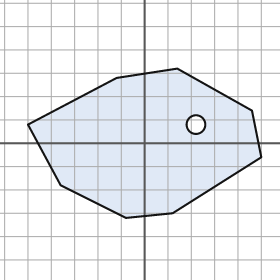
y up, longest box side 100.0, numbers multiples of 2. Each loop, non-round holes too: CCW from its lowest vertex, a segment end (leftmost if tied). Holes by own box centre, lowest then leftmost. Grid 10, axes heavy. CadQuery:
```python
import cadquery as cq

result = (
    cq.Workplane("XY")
    .moveTo(-8.0, -32.0)
    .lineTo(12.0, -30.0)
    .lineTo(50.0, -6.0)
    .lineTo(46.0, 14.0)
    .lineTo(14.0, 32.0)
    .lineTo(-12.0, 28.0)
    .lineTo(-50.0, 8.0)
    .lineTo(-36.0, -18.0)
    .close()
    .moveTo(22.0, 8.0)
    .circle(4.0)
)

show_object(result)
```